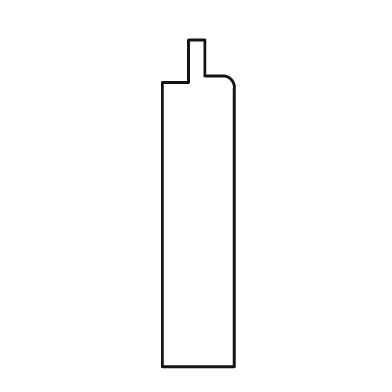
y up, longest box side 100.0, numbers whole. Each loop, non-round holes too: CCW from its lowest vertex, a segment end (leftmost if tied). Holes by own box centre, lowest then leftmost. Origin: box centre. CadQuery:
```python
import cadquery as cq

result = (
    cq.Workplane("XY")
    .moveTo(-11.0, -50.0)
    .lineTo(11.0, -50.0)
    .lineTo(11.0, 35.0)
    .threePointArc((10.0, 38.0), (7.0, 39.0))
    .lineTo(2.0, 39.0)
    .lineTo(2.0, 50.0)
    .lineTo(-3.0, 50.0)
    .lineTo(-3.0, 37.0)
    .lineTo(-11.0, 37.0)
    .close()
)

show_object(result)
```